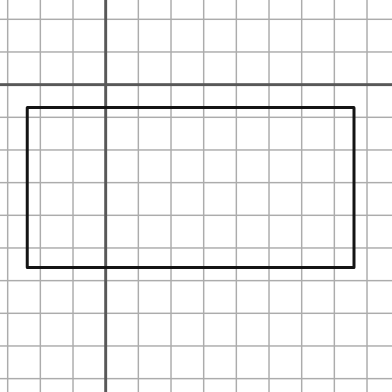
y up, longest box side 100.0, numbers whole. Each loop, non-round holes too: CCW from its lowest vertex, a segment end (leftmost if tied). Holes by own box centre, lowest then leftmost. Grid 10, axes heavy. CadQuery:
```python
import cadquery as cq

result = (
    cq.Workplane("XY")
    .moveTo(-24.0, -56.0)
    .lineTo(76.0, -56.0)
    .lineTo(76.0, -7.0)
    .lineTo(-24.0, -7.0)
    .close()
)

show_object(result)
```